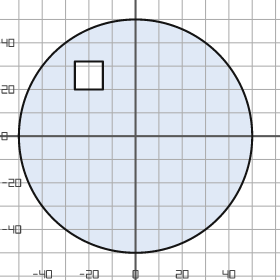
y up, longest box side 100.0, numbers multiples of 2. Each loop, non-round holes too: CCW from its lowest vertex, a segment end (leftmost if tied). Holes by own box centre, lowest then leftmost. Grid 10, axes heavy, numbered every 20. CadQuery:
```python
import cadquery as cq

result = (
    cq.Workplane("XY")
    .moveTo(0.0, 0.0)
    .circle(50.0)
    .moveTo(-26.0, 20.0)
    .lineTo(-14.0, 20.0)
    .lineTo(-14.0, 32.0)
    .lineTo(-26.0, 32.0)
    .close()
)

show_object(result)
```